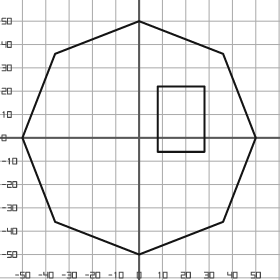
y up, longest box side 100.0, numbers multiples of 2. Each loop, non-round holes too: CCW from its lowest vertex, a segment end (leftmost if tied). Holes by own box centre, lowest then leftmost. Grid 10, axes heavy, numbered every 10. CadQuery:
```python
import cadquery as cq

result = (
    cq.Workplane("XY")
    .moveTo(0.0, -50.0)
    .lineTo(36.0, -36.0)
    .lineTo(50.0, 0.0)
    .lineTo(36.0, 36.0)
    .lineTo(0.0, 50.0)
    .lineTo(-36.0, 36.0)
    .lineTo(-50.0, 0.0)
    .lineTo(-36.0, -36.0)
    .close()
    .moveTo(8.0, -6.0)
    .lineTo(28.0, -6.0)
    .lineTo(28.0, 22.0)
    .lineTo(8.0, 22.0)
    .close()
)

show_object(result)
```